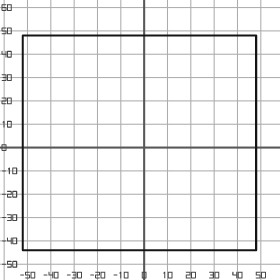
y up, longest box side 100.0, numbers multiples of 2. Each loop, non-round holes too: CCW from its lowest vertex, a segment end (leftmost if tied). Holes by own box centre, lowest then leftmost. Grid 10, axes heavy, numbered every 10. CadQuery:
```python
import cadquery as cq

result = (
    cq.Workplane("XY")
    .moveTo(-52.0, -44.0)
    .lineTo(48.0, -44.0)
    .lineTo(48.0, 48.0)
    .lineTo(-52.0, 48.0)
    .close()
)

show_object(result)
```